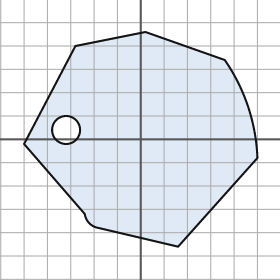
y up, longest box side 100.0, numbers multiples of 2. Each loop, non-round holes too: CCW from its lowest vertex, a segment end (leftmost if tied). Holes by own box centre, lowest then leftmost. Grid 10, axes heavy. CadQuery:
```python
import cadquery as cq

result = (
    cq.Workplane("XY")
    .moveTo(16.0, -46.0)
    .lineTo(50.0, -8.0)
    .threePointArc((46.0, 14.0), (36.0, 34.0))
    .lineTo(2.0, 46.0)
    .lineTo(-28.0, 40.0)
    .lineTo(-50.0, -2.0)
    .lineTo(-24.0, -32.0)
    .threePointArc((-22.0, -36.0), (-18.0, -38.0))
    .close()
    .moveTo(-32.0, 4.0)
    .circle(6.0)
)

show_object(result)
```